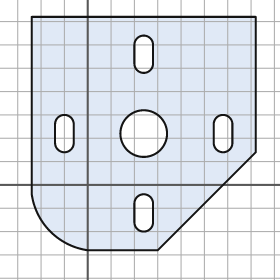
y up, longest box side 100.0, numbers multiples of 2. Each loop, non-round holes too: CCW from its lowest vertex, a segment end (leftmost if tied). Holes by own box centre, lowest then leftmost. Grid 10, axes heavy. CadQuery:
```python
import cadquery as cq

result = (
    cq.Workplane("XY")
    .moveTo(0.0, -28.0)
    .lineTo(30.0, -28.0)
    .lineTo(72.0, 14.0)
    .lineTo(72.0, 72.0)
    .lineTo(-24.0, 72.0)
    .lineTo(-24.0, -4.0)
    .threePointArc((-16.0, -20.0), (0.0, -28.0))
    .close()
    .moveTo(20.0, -16.0)
    .threePointArc((24.0, -20.0), (28.0, -16.0))
    .lineTo(28.0, -8.0)
    .threePointArc((24.0, -4.0), (20.0, -8.0))
    .close()
    .moveTo(-14.0, 18.0)
    .threePointArc((-10.0, 14.0), (-6.0, 18.0))
    .lineTo(-6.0, 26.0)
    .threePointArc((-10.0, 30.0), (-14.0, 26.0))
    .close()
    .moveTo(24.0, 22.0)
    .circle(10.0)
    .moveTo(54.0, 18.0)
    .threePointArc((58.0, 14.0), (62.0, 18.0))
    .lineTo(62.0, 26.0)
    .threePointArc((58.0, 30.0), (54.0, 26.0))
    .close()
    .moveTo(20.0, 52.0)
    .threePointArc((24.0, 48.0), (28.0, 52.0))
    .lineTo(28.0, 60.0)
    .threePointArc((24.0, 64.0), (20.0, 60.0))
    .close()
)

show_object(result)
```